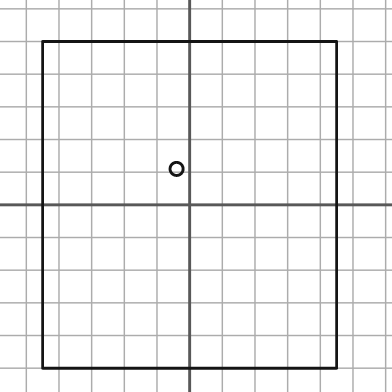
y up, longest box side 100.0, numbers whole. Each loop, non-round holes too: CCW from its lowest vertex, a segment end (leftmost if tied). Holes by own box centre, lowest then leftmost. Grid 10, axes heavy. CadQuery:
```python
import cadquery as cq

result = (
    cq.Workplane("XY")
    .moveTo(-45.0, -50.0)
    .lineTo(45.0, -50.0)
    .lineTo(45.0, 50.0)
    .lineTo(-45.0, 50.0)
    .close()
    .moveTo(-4.0, 11.0)
    .circle(2.0)
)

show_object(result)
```